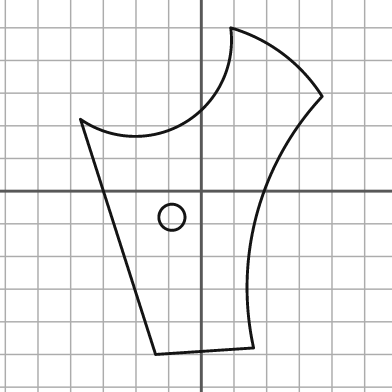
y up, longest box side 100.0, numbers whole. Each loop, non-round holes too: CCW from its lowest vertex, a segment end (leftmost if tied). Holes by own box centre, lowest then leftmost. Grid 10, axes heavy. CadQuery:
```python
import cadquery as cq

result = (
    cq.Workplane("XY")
    .moveTo(-14.0, -50.0)
    .lineTo(16.0, -48.0)
    .threePointArc((17.0, -7.0), (37.0, 29.0))
    .threePointArc((25.0, 42.0), (9.0, 50.0))
    .threePointArc((-5.0, 21.0), (-37.0, 22.0))
    .close()
    .moveTo(-9.0, -8.0)
    .circle(4.0)
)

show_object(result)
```